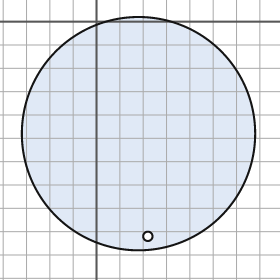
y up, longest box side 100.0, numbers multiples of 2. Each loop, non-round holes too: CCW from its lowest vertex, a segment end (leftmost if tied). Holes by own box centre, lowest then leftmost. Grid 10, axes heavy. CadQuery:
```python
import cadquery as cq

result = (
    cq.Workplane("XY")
    .moveTo(18.0, -48.0)
    .circle(50.0)
    .moveTo(22.0, -92.0)
    .circle(2.0)
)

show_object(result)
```